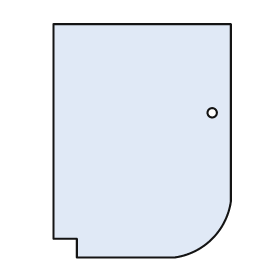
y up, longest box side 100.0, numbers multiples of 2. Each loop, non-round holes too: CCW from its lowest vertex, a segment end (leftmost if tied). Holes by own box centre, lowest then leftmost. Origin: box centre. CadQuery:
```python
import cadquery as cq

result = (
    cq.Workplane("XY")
    .moveTo(-28.0, -50.0)
    .lineTo(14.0, -50.0)
    .threePointArc((30.0, -42.0), (38.0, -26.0))
    .lineTo(38.0, 50.0)
    .lineTo(-38.0, 50.0)
    .lineTo(-38.0, -42.0)
    .lineTo(-28.0, -42.0)
    .close()
    .moveTo(30.0, 12.0)
    .circle(2.0)
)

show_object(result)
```